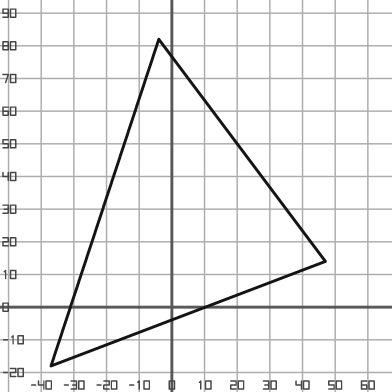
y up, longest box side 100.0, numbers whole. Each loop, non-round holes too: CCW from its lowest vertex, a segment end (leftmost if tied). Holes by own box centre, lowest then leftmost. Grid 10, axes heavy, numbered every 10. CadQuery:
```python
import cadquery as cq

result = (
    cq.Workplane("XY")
    .moveTo(-37.0, -18.0)
    .lineTo(47.0, 14.0)
    .lineTo(-4.0, 82.0)
    .close()
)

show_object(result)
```